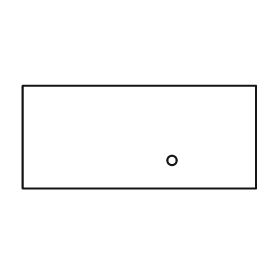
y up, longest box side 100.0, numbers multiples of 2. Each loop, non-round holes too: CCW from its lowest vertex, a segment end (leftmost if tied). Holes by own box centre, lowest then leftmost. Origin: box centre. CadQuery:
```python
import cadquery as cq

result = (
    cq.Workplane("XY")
    .moveTo(-50.0, -22.0)
    .lineTo(50.0, -22.0)
    .lineTo(50.0, 22.0)
    .lineTo(-50.0, 22.0)
    .close()
    .moveTo(14.0, -10.0)
    .circle(2.0)
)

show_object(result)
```